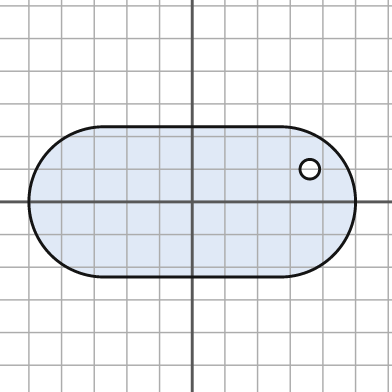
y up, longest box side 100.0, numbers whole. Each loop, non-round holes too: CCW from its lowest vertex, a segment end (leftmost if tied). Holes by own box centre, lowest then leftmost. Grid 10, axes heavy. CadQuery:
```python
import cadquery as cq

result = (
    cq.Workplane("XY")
    .moveTo(-27.0, -23.0)
    .lineTo(27.0, -23.0)
    .threePointArc((50.0, 0.0), (27.0, 23.0))
    .lineTo(-27.0, 23.0)
    .threePointArc((-50.0, 0.0), (-27.0, -23.0))
    .close()
    .moveTo(36.0, 10.0)
    .circle(3.0)
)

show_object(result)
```